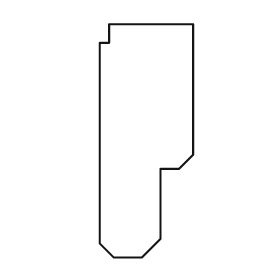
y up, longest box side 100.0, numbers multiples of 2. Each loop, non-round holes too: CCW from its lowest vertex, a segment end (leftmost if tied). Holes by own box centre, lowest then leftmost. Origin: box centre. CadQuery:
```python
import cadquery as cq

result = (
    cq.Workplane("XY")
    .moveTo(-14.0, -50.0)
    .lineTo(-2.0, -50.0)
    .lineTo(6.0, -42.0)
    .lineTo(6.0, -12.0)
    .lineTo(14.0, -12.0)
    .lineTo(20.0, -6.0)
    .lineTo(20.0, 50.0)
    .lineTo(-16.0, 50.0)
    .lineTo(-16.0, 42.0)
    .lineTo(-20.0, 42.0)
    .lineTo(-20.0, -44.0)
    .close()
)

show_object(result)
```